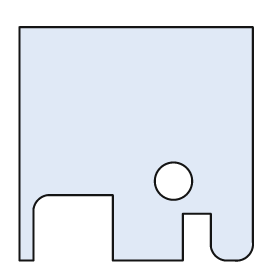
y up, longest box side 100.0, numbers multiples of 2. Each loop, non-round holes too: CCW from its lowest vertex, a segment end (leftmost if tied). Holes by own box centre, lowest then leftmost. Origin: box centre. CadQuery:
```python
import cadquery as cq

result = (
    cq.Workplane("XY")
    .moveTo(-50.0, -50.0)
    .lineTo(-44.0, -50.0)
    .lineTo(-44.0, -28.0)
    .threePointArc((-42.0, -24.0), (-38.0, -22.0))
    .lineTo(-10.0, -22.0)
    .lineTo(-10.0, -50.0)
    .lineTo(20.0, -50.0)
    .lineTo(20.0, -30.0)
    .lineTo(32.0, -30.0)
    .lineTo(32.0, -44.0)
    .threePointArc((34.0, -48.0), (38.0, -50.0))
    .lineTo(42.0, -50.0)
    .threePointArc((48.0, -48.0), (50.0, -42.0))
    .lineTo(50.0, 50.0)
    .lineTo(-50.0, 50.0)
    .close()
    .moveTo(16.0, -16.0)
    .circle(8.0)
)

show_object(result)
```